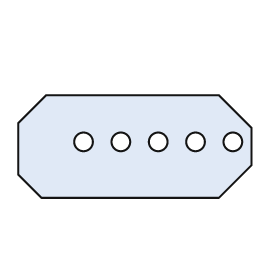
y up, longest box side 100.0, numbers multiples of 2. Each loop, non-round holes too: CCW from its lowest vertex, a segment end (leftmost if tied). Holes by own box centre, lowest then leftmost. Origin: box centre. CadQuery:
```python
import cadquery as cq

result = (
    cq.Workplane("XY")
    .moveTo(-40.0, -22.0)
    .lineTo(36.0, -22.0)
    .lineTo(50.0, -8.0)
    .lineTo(50.0, 8.0)
    .lineTo(36.0, 22.0)
    .lineTo(-38.0, 22.0)
    .lineTo(-50.0, 10.0)
    .lineTo(-50.0, -12.0)
    .close()
    .moveTo(-22.0, 2.0)
    .circle(4.0)
    .moveTo(-6.0, 2.0)
    .circle(4.0)
    .moveTo(10.0, 2.0)
    .circle(4.0)
    .moveTo(26.0, 2.0)
    .circle(4.0)
    .moveTo(42.0, 2.0)
    .circle(4.0)
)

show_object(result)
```